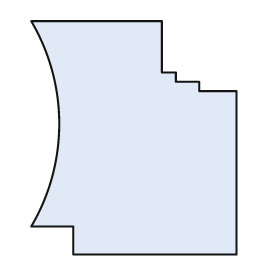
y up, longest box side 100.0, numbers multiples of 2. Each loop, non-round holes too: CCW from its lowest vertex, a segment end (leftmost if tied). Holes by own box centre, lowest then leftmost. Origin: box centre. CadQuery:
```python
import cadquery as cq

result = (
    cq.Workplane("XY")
    .moveTo(-26.0, -50.0)
    .lineTo(44.0, -50.0)
    .lineTo(44.0, 20.0)
    .lineTo(28.0, 20.0)
    .lineTo(28.0, 24.0)
    .lineTo(18.0, 24.0)
    .lineTo(18.0, 28.0)
    .lineTo(12.0, 28.0)
    .lineTo(12.0, 50.0)
    .lineTo(-44.0, 50.0)
    .threePointArc((-32.0, 6.0), (-44.0, -38.0))
    .lineTo(-26.0, -38.0)
    .close()
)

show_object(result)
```